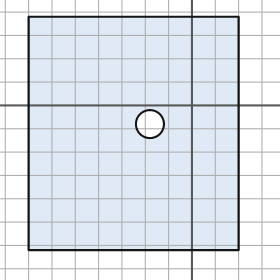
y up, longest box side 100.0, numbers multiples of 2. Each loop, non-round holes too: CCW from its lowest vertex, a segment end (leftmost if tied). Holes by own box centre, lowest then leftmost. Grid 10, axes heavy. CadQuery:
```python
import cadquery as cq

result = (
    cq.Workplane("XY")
    .moveTo(-70.0, -62.0)
    .lineTo(20.0, -62.0)
    .lineTo(20.0, 38.0)
    .lineTo(-70.0, 38.0)
    .close()
    .moveTo(-18.0, -8.0)
    .circle(6.0)
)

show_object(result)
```